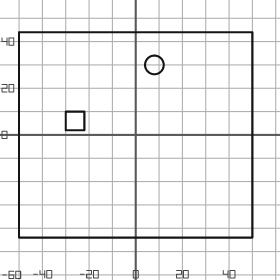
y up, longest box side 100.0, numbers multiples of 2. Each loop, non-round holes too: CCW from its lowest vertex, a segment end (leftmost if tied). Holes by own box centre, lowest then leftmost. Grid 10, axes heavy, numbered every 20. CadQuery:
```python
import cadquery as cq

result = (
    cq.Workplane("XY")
    .moveTo(-50.0, -44.0)
    .lineTo(50.0, -44.0)
    .lineTo(50.0, 44.0)
    .lineTo(-50.0, 44.0)
    .close()
    .moveTo(-30.0, 2.0)
    .lineTo(-22.0, 2.0)
    .lineTo(-22.0, 10.0)
    .lineTo(-30.0, 10.0)
    .close()
    .moveTo(8.0, 30.0)
    .circle(4.0)
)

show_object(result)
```